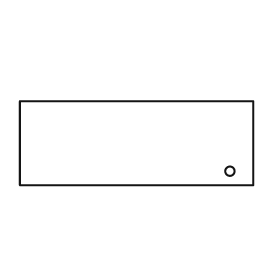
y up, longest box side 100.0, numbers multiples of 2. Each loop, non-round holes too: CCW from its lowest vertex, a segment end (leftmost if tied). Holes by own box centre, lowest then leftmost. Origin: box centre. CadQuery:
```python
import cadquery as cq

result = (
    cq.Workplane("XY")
    .moveTo(-50.0, -18.0)
    .lineTo(50.0, -18.0)
    .lineTo(50.0, 18.0)
    .lineTo(-50.0, 18.0)
    .close()
    .moveTo(40.0, -12.0)
    .circle(2.0)
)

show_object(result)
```